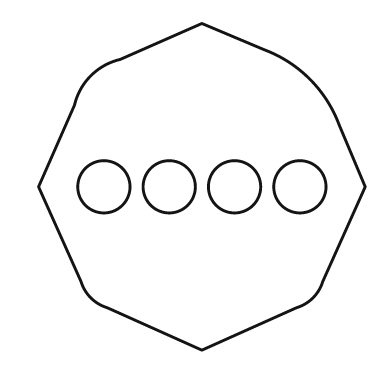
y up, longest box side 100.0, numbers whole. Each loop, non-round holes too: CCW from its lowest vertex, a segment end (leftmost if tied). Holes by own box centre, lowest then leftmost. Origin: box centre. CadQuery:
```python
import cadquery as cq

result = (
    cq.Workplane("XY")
    .moveTo(0.0, -50.0)
    .lineTo(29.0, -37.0)
    .threePointArc((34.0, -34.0), (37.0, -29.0))
    .lineTo(50.0, 0.0)
    .lineTo(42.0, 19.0)
    .threePointArc((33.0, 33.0), (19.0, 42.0))
    .lineTo(0.0, 50.0)
    .lineTo(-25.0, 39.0)
    .threePointArc((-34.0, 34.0), (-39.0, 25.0))
    .lineTo(-50.0, 0.0)
    .lineTo(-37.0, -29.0)
    .threePointArc((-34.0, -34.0), (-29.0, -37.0))
    .close()
    .moveTo(-30.0, 0.0)
    .circle(8.0)
    .moveTo(-10.0, 0.0)
    .circle(8.0)
    .moveTo(10.0, 0.0)
    .circle(8.0)
    .moveTo(30.0, 0.0)
    .circle(8.0)
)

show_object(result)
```